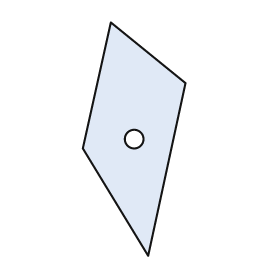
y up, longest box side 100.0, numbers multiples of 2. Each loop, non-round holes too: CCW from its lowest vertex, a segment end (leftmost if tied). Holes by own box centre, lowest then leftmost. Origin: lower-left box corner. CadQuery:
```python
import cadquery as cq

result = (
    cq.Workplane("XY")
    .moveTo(28.0, 0.0)
    .lineTo(44.0, 74.0)
    .lineTo(12.0, 100.0)
    .lineTo(0.0, 46.0)
    .close()
    .moveTo(22.0, 50.0)
    .circle(4.0)
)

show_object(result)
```